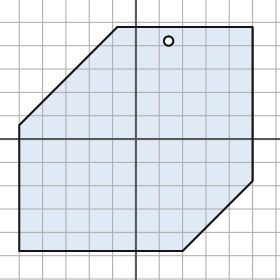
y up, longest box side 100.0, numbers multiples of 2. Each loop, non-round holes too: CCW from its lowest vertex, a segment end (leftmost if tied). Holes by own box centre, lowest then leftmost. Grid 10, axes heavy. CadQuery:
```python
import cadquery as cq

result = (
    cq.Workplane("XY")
    .moveTo(-50.0, -48.0)
    .lineTo(20.0, -48.0)
    .lineTo(50.0, -18.0)
    .lineTo(50.0, 48.0)
    .lineTo(-8.0, 48.0)
    .lineTo(-50.0, 6.0)
    .close()
    .moveTo(14.0, 42.0)
    .circle(2.0)
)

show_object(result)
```